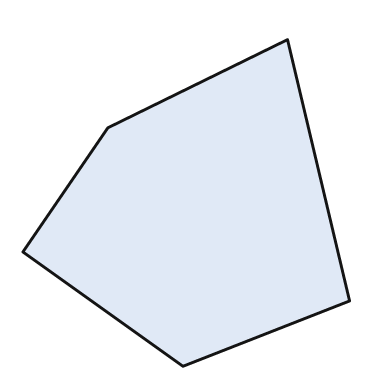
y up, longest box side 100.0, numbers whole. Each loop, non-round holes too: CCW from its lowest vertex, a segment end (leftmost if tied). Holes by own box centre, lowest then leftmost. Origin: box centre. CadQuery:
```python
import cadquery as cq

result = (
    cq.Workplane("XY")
    .moveTo(-1.0, -50.0)
    .lineTo(50.0, -30.0)
    .lineTo(31.0, 50.0)
    .lineTo(-24.0, 23.0)
    .lineTo(-50.0, -15.0)
    .close()
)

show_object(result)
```